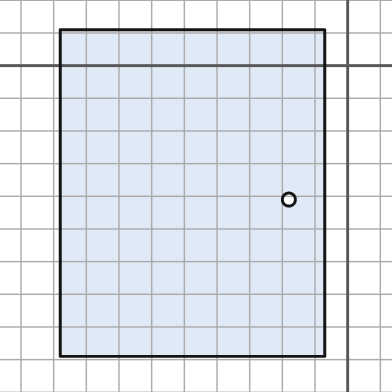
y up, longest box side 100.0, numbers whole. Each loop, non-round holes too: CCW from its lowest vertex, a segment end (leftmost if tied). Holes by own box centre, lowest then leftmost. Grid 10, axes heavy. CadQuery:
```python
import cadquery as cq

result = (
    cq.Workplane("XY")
    .moveTo(-88.0, -89.0)
    .lineTo(-7.0, -89.0)
    .lineTo(-7.0, 11.0)
    .lineTo(-88.0, 11.0)
    .close()
    .moveTo(-18.0, -41.0)
    .circle(2.0)
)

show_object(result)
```